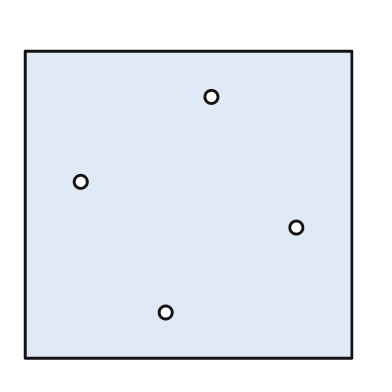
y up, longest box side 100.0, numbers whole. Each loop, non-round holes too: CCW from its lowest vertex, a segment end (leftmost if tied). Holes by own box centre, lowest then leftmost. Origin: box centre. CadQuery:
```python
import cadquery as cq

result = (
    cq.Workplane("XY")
    .moveTo(-50.0, -47.0)
    .lineTo(50.0, -47.0)
    .lineTo(50.0, 47.0)
    .lineTo(-50.0, 47.0)
    .close()
    .moveTo(-7.0, -33.0)
    .circle(2.0)
    .moveTo(33.0, -7.0)
    .circle(2.0)
    .moveTo(-33.0, 7.0)
    .circle(2.0)
    .moveTo(7.0, 33.0)
    .circle(2.0)
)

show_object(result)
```